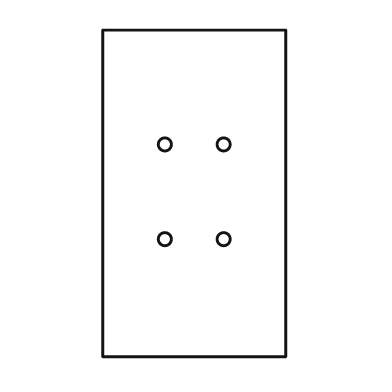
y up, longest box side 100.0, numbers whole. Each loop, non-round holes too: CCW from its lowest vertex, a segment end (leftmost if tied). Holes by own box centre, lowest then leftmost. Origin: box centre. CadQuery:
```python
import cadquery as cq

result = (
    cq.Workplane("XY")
    .moveTo(-28.0, -50.0)
    .lineTo(28.0, -50.0)
    .lineTo(28.0, 50.0)
    .lineTo(-28.0, 50.0)
    .close()
    .moveTo(-9.0, -14.0)
    .circle(2.0)
    .moveTo(9.0, -14.0)
    .circle(2.0)
    .moveTo(-9.0, 15.0)
    .circle(2.0)
    .moveTo(9.0, 15.0)
    .circle(2.0)
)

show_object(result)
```